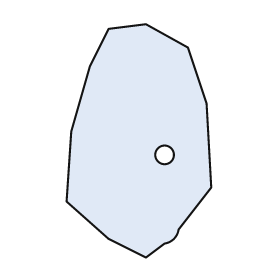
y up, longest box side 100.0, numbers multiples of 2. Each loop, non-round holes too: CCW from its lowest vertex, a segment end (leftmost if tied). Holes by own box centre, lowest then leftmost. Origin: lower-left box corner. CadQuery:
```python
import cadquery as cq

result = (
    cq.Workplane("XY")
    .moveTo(34.0, 0.0)
    .lineTo(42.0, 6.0)
    .threePointArc((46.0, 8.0), (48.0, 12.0))
    .lineTo(62.0, 30.0)
    .lineTo(60.0, 66.0)
    .lineTo(52.0, 90.0)
    .lineTo(34.0, 100.0)
    .lineTo(18.0, 98.0)
    .lineTo(10.0, 82.0)
    .lineTo(2.0, 54.0)
    .lineTo(0.0, 24.0)
    .lineTo(18.0, 8.0)
    .close()
    .moveTo(42.0, 44.0)
    .circle(4.0)
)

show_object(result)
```